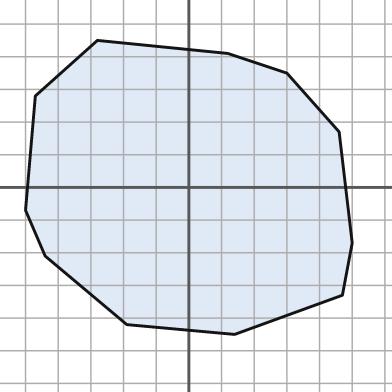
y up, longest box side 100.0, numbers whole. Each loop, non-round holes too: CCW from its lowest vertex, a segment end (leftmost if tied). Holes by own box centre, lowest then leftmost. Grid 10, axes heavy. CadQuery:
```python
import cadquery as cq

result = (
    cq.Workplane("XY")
    .moveTo(14.0, -45.0)
    .lineTo(47.0, -33.0)
    .lineTo(50.0, -17.0)
    .lineTo(46.0, 17.0)
    .lineTo(30.0, 35.0)
    .lineTo(12.0, 41.0)
    .lineTo(-28.0, 45.0)
    .lineTo(-47.0, 28.0)
    .lineTo(-50.0, -7.0)
    .lineTo(-44.0, -21.0)
    .lineTo(-19.0, -42.0)
    .close()
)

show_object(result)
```